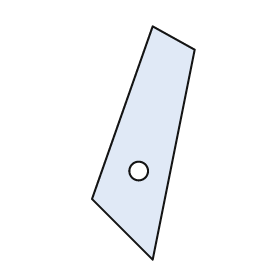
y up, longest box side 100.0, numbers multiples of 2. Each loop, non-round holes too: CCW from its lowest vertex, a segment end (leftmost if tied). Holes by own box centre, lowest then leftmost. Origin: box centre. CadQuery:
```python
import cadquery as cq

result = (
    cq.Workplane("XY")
    .moveTo(4.0, -50.0)
    .lineTo(22.0, 40.0)
    .lineTo(4.0, 50.0)
    .lineTo(-22.0, -24.0)
    .close()
    .moveTo(-2.0, -12.0)
    .circle(4.0)
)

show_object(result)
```